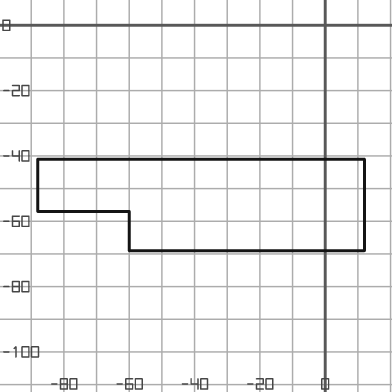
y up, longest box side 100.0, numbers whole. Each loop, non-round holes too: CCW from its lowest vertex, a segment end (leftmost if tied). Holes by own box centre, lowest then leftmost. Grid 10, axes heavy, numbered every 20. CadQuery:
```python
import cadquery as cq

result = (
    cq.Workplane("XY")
    .moveTo(-60.0, -69.0)
    .lineTo(12.0, -69.0)
    .lineTo(12.0, -41.0)
    .lineTo(-88.0, -41.0)
    .lineTo(-88.0, -57.0)
    .lineTo(-60.0, -57.0)
    .close()
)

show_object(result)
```